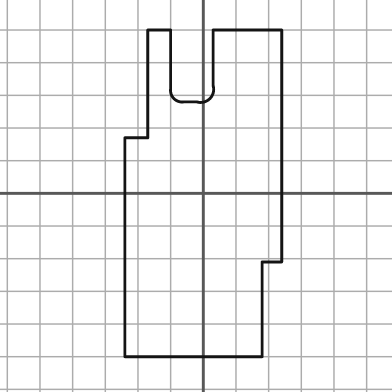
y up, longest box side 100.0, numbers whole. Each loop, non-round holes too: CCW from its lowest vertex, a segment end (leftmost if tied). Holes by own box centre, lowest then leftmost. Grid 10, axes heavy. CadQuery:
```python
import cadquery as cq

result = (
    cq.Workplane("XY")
    .moveTo(-24.0, -50.0)
    .lineTo(18.0, -50.0)
    .lineTo(18.0, -21.0)
    .lineTo(24.0, -21.0)
    .lineTo(24.0, 50.0)
    .lineTo(3.0, 50.0)
    .lineTo(3.0, 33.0)
    .threePointArc((2.0, 29.0), (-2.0, 28.0))
    .lineTo(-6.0, 28.0)
    .threePointArc((-9.0, 29.0), (-10.0, 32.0))
    .lineTo(-10.0, 50.0)
    .lineTo(-17.0, 50.0)
    .lineTo(-17.0, 17.0)
    .lineTo(-24.0, 17.0)
    .close()
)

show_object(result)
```